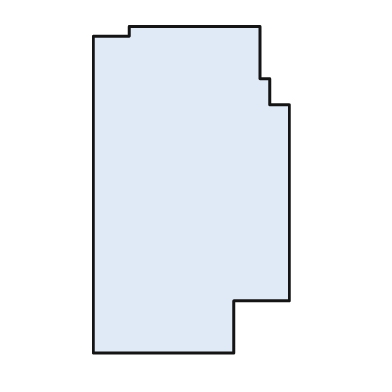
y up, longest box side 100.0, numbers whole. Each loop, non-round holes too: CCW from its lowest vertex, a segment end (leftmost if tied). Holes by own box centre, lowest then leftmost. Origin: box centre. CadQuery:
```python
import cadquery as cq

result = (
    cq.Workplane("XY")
    .moveTo(-30.0, -50.0)
    .lineTo(13.0, -50.0)
    .lineTo(13.0, -34.0)
    .lineTo(30.0, -34.0)
    .lineTo(30.0, 26.0)
    .lineTo(24.0, 26.0)
    .lineTo(24.0, 34.0)
    .lineTo(21.0, 34.0)
    .lineTo(21.0, 50.0)
    .lineTo(-19.0, 50.0)
    .lineTo(-19.0, 47.0)
    .lineTo(-30.0, 47.0)
    .close()
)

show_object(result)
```